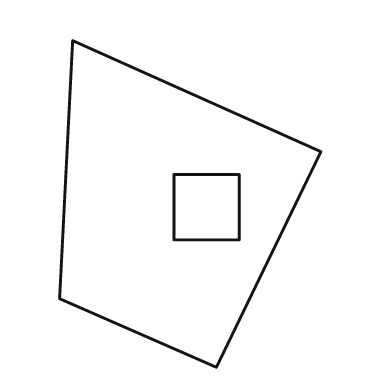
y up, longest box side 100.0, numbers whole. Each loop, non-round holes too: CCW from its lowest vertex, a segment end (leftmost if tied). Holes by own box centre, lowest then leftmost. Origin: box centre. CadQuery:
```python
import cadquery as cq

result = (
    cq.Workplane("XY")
    .moveTo(8.0, -50.0)
    .lineTo(40.0, 16.0)
    .lineTo(-36.0, 50.0)
    .lineTo(-40.0, -29.0)
    .close()
    .moveTo(-5.0, -11.0)
    .lineTo(15.0, -11.0)
    .lineTo(15.0, 9.0)
    .lineTo(-5.0, 9.0)
    .close()
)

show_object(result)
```